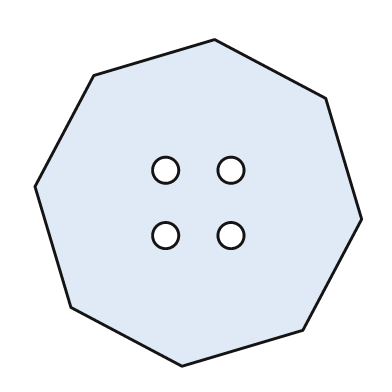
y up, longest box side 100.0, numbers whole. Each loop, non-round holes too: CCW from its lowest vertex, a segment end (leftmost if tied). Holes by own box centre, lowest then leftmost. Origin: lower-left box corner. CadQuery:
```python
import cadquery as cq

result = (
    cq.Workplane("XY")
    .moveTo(45.0, 0.0)
    .lineTo(82.0, 11.0)
    .lineTo(100.0, 45.0)
    .lineTo(89.0, 82.0)
    .lineTo(55.0, 100.0)
    .lineTo(18.0, 89.0)
    .lineTo(0.0, 55.0)
    .lineTo(11.0, 18.0)
    .close()
    .moveTo(40.0, 40.0)
    .circle(4.0)
    .moveTo(60.0, 40.0)
    .circle(4.0)
    .moveTo(40.0, 60.0)
    .circle(4.0)
    .moveTo(60.0, 60.0)
    .circle(4.0)
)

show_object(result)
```